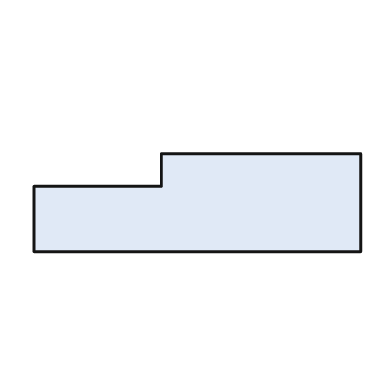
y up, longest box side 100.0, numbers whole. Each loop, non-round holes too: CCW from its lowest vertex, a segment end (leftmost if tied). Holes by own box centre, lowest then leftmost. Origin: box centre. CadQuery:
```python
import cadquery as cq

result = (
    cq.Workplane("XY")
    .moveTo(-50.0, -15.0)
    .lineTo(50.0, -15.0)
    .lineTo(50.0, 15.0)
    .lineTo(-11.0, 15.0)
    .lineTo(-11.0, 5.0)
    .lineTo(-50.0, 5.0)
    .close()
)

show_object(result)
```